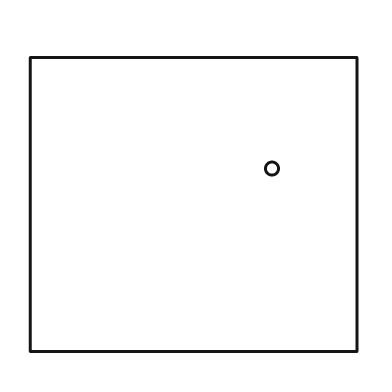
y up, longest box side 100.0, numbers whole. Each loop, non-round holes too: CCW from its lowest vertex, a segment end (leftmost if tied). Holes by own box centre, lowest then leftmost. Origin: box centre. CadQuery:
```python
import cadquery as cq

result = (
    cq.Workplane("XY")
    .moveTo(-50.0, -45.0)
    .lineTo(50.0, -45.0)
    .lineTo(50.0, 45.0)
    .lineTo(-50.0, 45.0)
    .close()
    .moveTo(24.0, 11.0)
    .circle(2.0)
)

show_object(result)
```